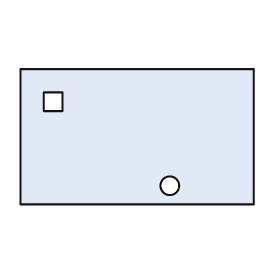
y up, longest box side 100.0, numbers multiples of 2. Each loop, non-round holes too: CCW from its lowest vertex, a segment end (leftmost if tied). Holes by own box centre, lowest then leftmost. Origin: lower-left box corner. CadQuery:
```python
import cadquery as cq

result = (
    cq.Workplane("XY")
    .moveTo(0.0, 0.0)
    .lineTo(100.0, 0.0)
    .lineTo(100.0, 58.0)
    .lineTo(0.0, 58.0)
    .close()
    .moveTo(64.0, 8.0)
    .circle(4.0)
    .moveTo(10.0, 40.0)
    .lineTo(18.0, 40.0)
    .lineTo(18.0, 48.0)
    .lineTo(10.0, 48.0)
    .close()
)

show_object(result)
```